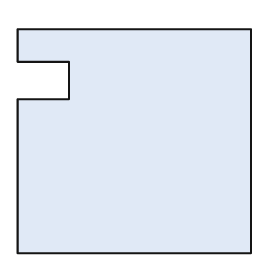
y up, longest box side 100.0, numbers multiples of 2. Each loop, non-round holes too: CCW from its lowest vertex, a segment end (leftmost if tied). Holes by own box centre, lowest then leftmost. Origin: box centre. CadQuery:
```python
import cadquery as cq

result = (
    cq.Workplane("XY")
    .moveTo(-50.0, -48.0)
    .lineTo(50.0, -48.0)
    .lineTo(50.0, 48.0)
    .lineTo(-50.0, 48.0)
    .lineTo(-50.0, 34.0)
    .lineTo(-28.0, 34.0)
    .lineTo(-28.0, 18.0)
    .lineTo(-50.0, 18.0)
    .close()
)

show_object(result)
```